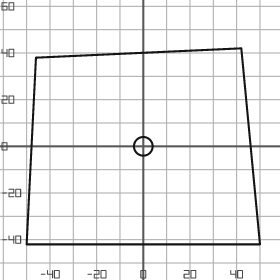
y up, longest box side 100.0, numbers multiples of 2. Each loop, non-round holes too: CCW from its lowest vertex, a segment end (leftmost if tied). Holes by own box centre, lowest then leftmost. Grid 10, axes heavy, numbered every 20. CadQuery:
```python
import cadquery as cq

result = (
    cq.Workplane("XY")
    .moveTo(-50.0, -42.0)
    .lineTo(50.0, -42.0)
    .lineTo(42.0, 42.0)
    .lineTo(-46.0, 38.0)
    .close()
    .moveTo(0.0, 0.0)
    .circle(4.0)
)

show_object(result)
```